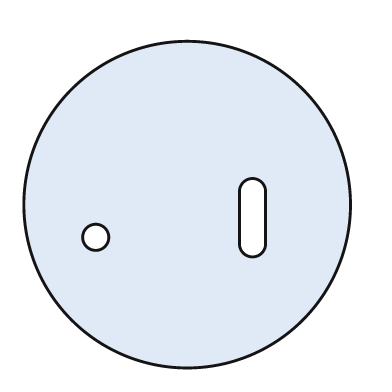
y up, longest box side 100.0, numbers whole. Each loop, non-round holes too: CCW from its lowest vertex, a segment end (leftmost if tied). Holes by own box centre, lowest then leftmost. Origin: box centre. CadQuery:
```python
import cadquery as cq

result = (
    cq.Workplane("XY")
    .moveTo(0.0, 0.0)
    .circle(50.0)
    .moveTo(-28.0, -10.0)
    .circle(4.0)
    .moveTo(16.0, -12.0)
    .threePointArc((20.0, -16.0), (24.0, -12.0))
    .lineTo(24.0, 4.0)
    .threePointArc((20.0, 8.0), (16.0, 4.0))
    .close()
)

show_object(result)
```